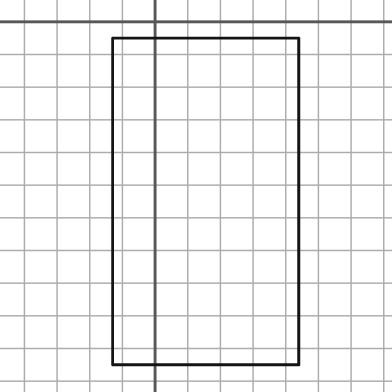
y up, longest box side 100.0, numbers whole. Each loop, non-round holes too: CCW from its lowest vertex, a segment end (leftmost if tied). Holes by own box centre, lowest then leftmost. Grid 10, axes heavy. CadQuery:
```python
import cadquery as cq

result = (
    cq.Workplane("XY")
    .moveTo(-13.0, -105.0)
    .lineTo(44.0, -105.0)
    .lineTo(44.0, -5.0)
    .lineTo(-13.0, -5.0)
    .close()
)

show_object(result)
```